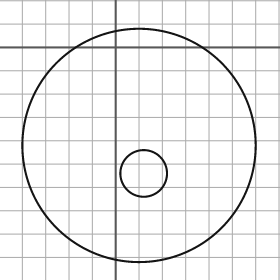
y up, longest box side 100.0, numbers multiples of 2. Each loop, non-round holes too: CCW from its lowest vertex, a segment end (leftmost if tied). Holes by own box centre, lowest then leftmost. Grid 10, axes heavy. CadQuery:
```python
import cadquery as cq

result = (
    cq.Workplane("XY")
    .moveTo(10.0, -42.0)
    .circle(50.0)
    .moveTo(12.0, -54.0)
    .circle(10.0)
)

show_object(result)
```